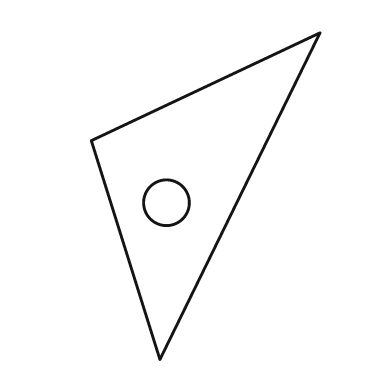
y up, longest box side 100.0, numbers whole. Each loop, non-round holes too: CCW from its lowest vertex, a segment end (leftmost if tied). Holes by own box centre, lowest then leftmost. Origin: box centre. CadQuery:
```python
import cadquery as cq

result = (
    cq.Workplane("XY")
    .moveTo(-14.0, -50.0)
    .lineTo(35.0, 50.0)
    .lineTo(-35.0, 17.0)
    .close()
    .moveTo(-12.0, -2.0)
    .circle(7.0)
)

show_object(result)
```